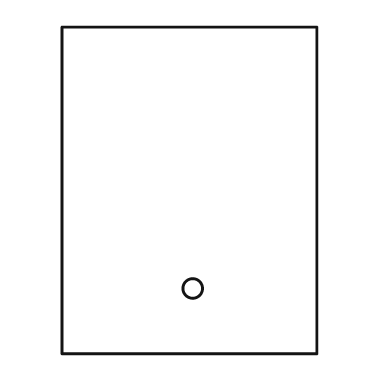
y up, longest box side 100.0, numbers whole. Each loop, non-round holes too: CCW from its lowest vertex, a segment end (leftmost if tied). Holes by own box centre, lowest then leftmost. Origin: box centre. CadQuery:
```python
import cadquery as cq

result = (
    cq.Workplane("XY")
    .moveTo(-39.0, -50.0)
    .lineTo(39.0, -50.0)
    .lineTo(39.0, 50.0)
    .lineTo(-39.0, 50.0)
    .close()
    .moveTo(1.0, -30.0)
    .circle(3.0)
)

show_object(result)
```